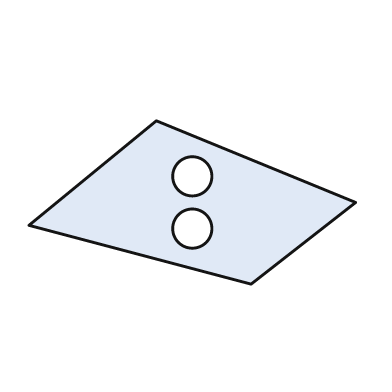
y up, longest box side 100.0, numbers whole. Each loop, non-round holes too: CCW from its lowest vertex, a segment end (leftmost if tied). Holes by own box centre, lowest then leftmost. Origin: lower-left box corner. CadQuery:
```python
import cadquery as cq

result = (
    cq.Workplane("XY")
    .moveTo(68.0, 0.0)
    .lineTo(100.0, 25.0)
    .lineTo(39.0, 50.0)
    .lineTo(0.0, 18.0)
    .close()
    .moveTo(50.0, 17.0)
    .circle(6.0)
    .moveTo(50.0, 33.0)
    .circle(6.0)
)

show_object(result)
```